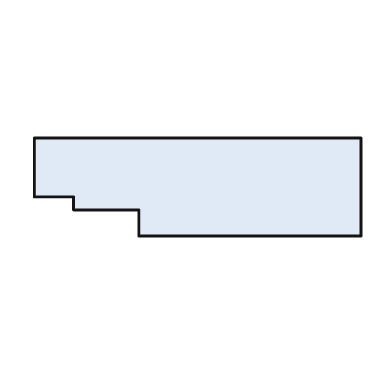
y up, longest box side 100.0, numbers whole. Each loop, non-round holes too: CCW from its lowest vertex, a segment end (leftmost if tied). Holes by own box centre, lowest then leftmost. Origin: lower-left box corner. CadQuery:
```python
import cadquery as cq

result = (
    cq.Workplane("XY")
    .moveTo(32.0, 0.0)
    .lineTo(100.0, 0.0)
    .lineTo(100.0, 30.0)
    .lineTo(0.0, 30.0)
    .lineTo(0.0, 12.0)
    .lineTo(12.0, 12.0)
    .lineTo(12.0, 8.0)
    .lineTo(32.0, 8.0)
    .close()
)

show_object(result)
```